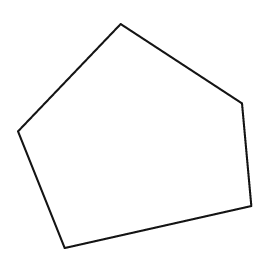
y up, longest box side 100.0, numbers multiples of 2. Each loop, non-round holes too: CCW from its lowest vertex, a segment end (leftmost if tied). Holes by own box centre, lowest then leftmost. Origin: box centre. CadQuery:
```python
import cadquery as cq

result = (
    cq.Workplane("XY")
    .moveTo(-30.0, -48.0)
    .lineTo(50.0, -30.0)
    .lineTo(46.0, 14.0)
    .lineTo(-6.0, 48.0)
    .lineTo(-50.0, 2.0)
    .close()
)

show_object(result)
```